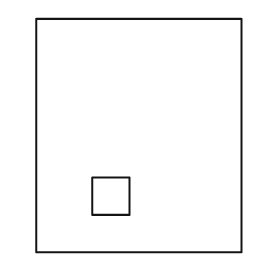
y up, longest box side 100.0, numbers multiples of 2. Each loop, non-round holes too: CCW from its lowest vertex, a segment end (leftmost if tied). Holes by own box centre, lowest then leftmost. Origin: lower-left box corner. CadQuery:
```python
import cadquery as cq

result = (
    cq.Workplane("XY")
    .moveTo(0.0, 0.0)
    .lineTo(88.0, 0.0)
    .lineTo(88.0, 100.0)
    .lineTo(0.0, 100.0)
    .close()
    .moveTo(24.0, 16.0)
    .lineTo(40.0, 16.0)
    .lineTo(40.0, 32.0)
    .lineTo(24.0, 32.0)
    .close()
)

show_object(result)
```